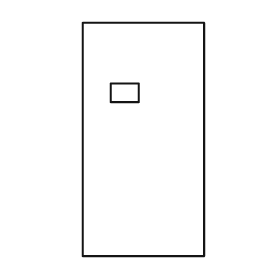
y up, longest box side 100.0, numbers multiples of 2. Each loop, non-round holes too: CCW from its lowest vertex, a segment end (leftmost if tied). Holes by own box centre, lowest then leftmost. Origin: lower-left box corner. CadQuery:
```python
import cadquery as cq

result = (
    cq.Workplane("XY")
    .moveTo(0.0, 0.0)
    .lineTo(52.0, 0.0)
    .lineTo(52.0, 100.0)
    .lineTo(0.0, 100.0)
    .close()
    .moveTo(12.0, 66.0)
    .lineTo(24.0, 66.0)
    .lineTo(24.0, 74.0)
    .lineTo(12.0, 74.0)
    .close()
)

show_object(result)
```